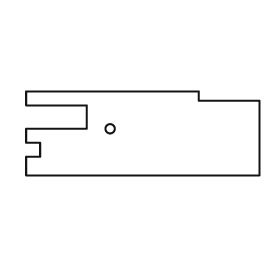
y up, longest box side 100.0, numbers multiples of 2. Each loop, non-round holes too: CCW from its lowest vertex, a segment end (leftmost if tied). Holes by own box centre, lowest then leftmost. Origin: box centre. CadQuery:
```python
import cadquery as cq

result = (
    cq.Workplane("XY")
    .moveTo(-50.0, -18.0)
    .lineTo(50.0, -18.0)
    .lineTo(50.0, 14.0)
    .lineTo(24.0, 14.0)
    .lineTo(24.0, 18.0)
    .lineTo(-50.0, 18.0)
    .lineTo(-50.0, 12.0)
    .lineTo(-24.0, 12.0)
    .lineTo(-24.0, 2.0)
    .lineTo(-50.0, 2.0)
    .lineTo(-50.0, -4.0)
    .lineTo(-44.0, -4.0)
    .lineTo(-44.0, -10.0)
    .lineTo(-50.0, -10.0)
    .close()
    .moveTo(-14.0, 2.0)
    .circle(2.0)
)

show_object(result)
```